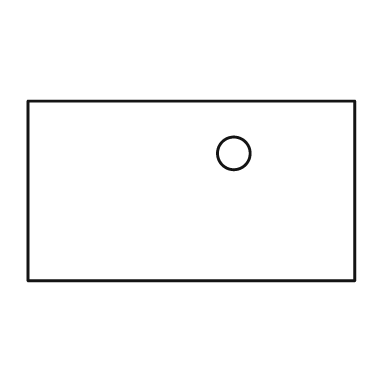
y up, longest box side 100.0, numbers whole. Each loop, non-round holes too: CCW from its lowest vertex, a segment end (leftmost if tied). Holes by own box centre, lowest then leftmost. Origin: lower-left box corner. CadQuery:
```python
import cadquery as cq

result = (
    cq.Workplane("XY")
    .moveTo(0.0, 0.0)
    .lineTo(100.0, 0.0)
    .lineTo(100.0, 55.0)
    .lineTo(0.0, 55.0)
    .close()
    .moveTo(63.0, 39.0)
    .circle(5.0)
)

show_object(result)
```